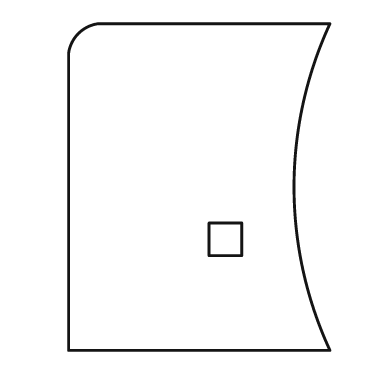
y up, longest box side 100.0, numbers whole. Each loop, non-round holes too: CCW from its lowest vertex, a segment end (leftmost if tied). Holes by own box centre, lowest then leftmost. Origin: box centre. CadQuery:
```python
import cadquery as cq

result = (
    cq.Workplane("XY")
    .moveTo(-40.0, -50.0)
    .lineTo(40.0, -50.0)
    .threePointArc((29.0, 0.0), (40.0, 50.0))
    .lineTo(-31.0, 50.0)
    .threePointArc((-37.0, 47.0), (-40.0, 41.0))
    .close()
    .moveTo(3.0, -21.0)
    .lineTo(13.0, -21.0)
    .lineTo(13.0, -11.0)
    .lineTo(3.0, -11.0)
    .close()
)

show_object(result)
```